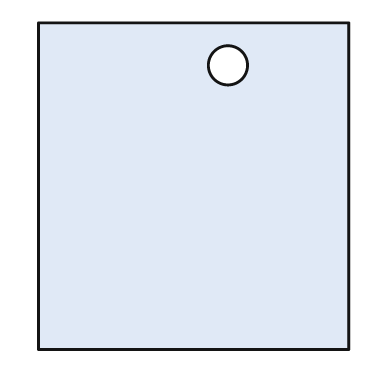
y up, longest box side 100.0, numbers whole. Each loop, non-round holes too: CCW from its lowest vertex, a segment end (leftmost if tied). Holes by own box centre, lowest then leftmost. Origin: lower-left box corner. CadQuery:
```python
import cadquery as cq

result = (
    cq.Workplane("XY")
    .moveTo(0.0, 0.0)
    .lineTo(95.0, 0.0)
    .lineTo(95.0, 100.0)
    .lineTo(0.0, 100.0)
    .close()
    .moveTo(58.0, 87.0)
    .circle(6.0)
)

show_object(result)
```